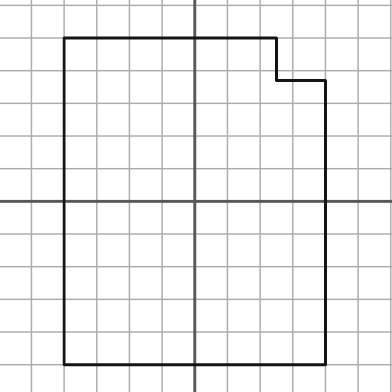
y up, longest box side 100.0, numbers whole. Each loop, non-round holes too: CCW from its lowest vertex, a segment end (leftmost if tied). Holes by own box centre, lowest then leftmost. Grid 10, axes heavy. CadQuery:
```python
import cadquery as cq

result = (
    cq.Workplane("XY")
    .moveTo(-40.0, -50.0)
    .lineTo(40.0, -50.0)
    .lineTo(40.0, 37.0)
    .lineTo(25.0, 37.0)
    .lineTo(25.0, 50.0)
    .lineTo(-40.0, 50.0)
    .close()
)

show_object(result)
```